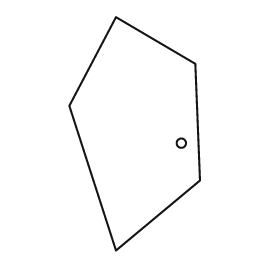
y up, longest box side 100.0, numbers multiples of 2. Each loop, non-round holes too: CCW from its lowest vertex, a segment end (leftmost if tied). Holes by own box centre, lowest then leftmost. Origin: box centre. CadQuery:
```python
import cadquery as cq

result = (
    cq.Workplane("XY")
    .moveTo(-8.0, -50.0)
    .lineTo(28.0, -20.0)
    .lineTo(26.0, 30.0)
    .lineTo(-8.0, 50.0)
    .lineTo(-28.0, 12.0)
    .close()
    .moveTo(20.0, -4.0)
    .circle(2.0)
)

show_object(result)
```